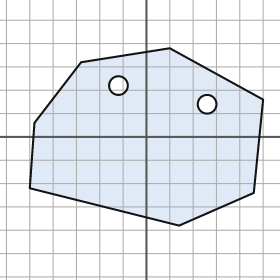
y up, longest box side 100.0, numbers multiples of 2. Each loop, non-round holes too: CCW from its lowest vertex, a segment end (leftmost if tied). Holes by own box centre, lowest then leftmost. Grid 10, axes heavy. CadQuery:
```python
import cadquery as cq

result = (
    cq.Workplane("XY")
    .moveTo(14.0, -38.0)
    .lineTo(46.0, -24.0)
    .lineTo(50.0, 16.0)
    .lineTo(10.0, 38.0)
    .lineTo(-28.0, 32.0)
    .lineTo(-48.0, 6.0)
    .lineTo(-50.0, -22.0)
    .close()
    .moveTo(26.0, 14.0)
    .circle(4.0)
    .moveTo(-12.0, 22.0)
    .circle(4.0)
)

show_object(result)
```